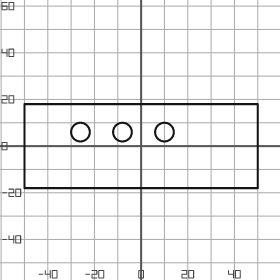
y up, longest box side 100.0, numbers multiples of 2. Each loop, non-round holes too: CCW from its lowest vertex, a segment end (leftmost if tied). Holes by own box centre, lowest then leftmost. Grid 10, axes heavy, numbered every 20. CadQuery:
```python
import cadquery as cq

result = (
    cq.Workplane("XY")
    .moveTo(-50.0, -18.0)
    .lineTo(50.0, -18.0)
    .lineTo(50.0, 18.0)
    .lineTo(-50.0, 18.0)
    .close()
    .moveTo(-26.0, 6.0)
    .circle(4.0)
    .moveTo(-8.0, 6.0)
    .circle(4.0)
    .moveTo(10.0, 6.0)
    .circle(4.0)
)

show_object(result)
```